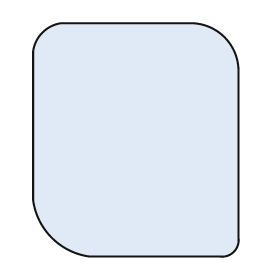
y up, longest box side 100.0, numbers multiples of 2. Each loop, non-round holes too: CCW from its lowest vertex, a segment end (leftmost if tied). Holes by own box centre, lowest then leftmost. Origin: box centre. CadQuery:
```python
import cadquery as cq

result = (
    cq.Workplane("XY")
    .moveTo(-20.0, -50.0)
    .lineTo(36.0, -50.0)
    .threePointArc((42.0, -48.0), (44.0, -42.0))
    .lineTo(44.0, 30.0)
    .threePointArc((38.0, 44.0), (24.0, 50.0))
    .lineTo(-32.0, 50.0)
    .threePointArc((-40.0, 46.0), (-44.0, 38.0))
    .lineTo(-44.0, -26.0)
    .threePointArc((-36.0, -42.0), (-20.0, -50.0))
    .close()
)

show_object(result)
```